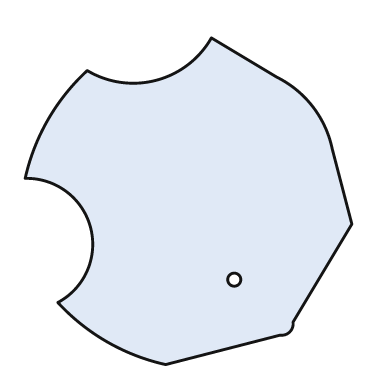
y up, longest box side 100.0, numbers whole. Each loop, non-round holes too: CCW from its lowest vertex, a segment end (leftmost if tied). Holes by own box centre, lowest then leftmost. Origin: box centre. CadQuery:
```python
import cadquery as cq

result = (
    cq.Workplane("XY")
    .moveTo(-7.0, -50.0)
    .lineTo(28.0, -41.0)
    .threePointArc((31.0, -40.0), (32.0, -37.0))
    .lineTo(50.0, -7.0)
    .lineTo(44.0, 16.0)
    .threePointArc((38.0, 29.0), (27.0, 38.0))
    .lineTo(7.0, 50.0)
    .threePointArc((-10.0, 37.0), (-31.0, 40.0))
    .threePointArc((-43.0, 25.0), (-50.0, 7.0))
    .threePointArc((-30.0, -8.0), (-40.0, -31.0))
    .threePointArc((-25.0, -43.0), (-7.0, -50.0))
    .close()
    .moveTo(14.0, -24.0)
    .circle(2.0)
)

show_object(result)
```